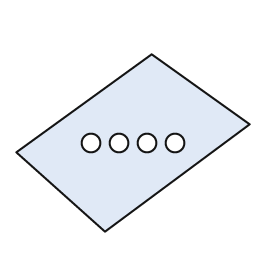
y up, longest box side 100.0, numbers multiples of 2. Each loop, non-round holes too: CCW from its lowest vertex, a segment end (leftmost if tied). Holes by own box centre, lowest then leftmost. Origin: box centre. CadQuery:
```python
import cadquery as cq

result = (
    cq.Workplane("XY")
    .moveTo(-12.0, -38.0)
    .lineTo(50.0, 8.0)
    .lineTo(8.0, 38.0)
    .lineTo(-50.0, -4.0)
    .close()
    .moveTo(-18.0, 0.0)
    .circle(4.0)
    .moveTo(-6.0, 0.0)
    .circle(4.0)
    .moveTo(6.0, 0.0)
    .circle(4.0)
    .moveTo(18.0, 0.0)
    .circle(4.0)
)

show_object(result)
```